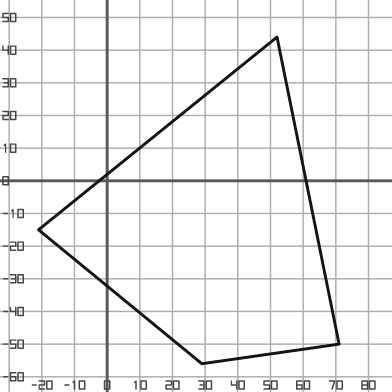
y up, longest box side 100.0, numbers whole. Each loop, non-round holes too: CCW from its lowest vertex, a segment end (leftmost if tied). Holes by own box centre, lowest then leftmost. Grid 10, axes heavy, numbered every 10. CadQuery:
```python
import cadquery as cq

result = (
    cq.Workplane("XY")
    .moveTo(29.0, -56.0)
    .lineTo(71.0, -50.0)
    .lineTo(52.0, 44.0)
    .lineTo(-21.0, -15.0)
    .close()
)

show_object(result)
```